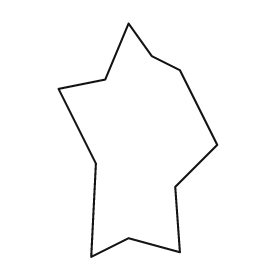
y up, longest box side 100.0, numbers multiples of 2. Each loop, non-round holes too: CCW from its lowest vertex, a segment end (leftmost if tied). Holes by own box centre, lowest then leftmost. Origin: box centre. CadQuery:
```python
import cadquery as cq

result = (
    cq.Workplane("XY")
    .moveTo(-20.0, -50.0)
    .lineTo(-4.0, -42.0)
    .lineTo(18.0, -48.0)
    .lineTo(16.0, -20.0)
    .lineTo(34.0, -2.0)
    .lineTo(18.0, 30.0)
    .lineTo(6.0, 36.0)
    .lineTo(-4.0, 50.0)
    .lineTo(-14.0, 26.0)
    .lineTo(-34.0, 22.0)
    .lineTo(-18.0, -10.0)
    .close()
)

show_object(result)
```